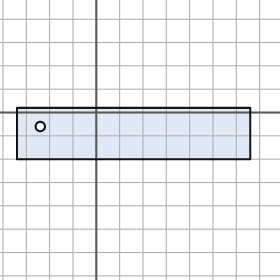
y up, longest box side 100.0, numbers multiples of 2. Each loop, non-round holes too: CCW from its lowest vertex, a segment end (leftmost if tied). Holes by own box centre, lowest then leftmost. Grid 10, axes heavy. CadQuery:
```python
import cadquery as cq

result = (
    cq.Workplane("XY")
    .moveTo(-34.0, -20.0)
    .lineTo(66.0, -20.0)
    .lineTo(66.0, 2.0)
    .lineTo(-34.0, 2.0)
    .close()
    .moveTo(-24.0, -6.0)
    .circle(2.0)
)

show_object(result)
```